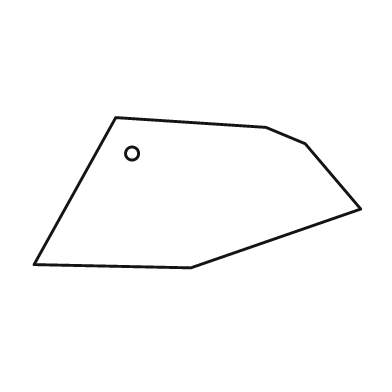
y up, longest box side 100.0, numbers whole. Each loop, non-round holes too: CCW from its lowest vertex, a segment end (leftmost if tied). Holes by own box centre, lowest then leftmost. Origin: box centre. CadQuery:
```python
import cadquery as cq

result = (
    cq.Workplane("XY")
    .moveTo(-2.0, -23.0)
    .lineTo(50.0, -5.0)
    .lineTo(33.0, 15.0)
    .lineTo(21.0, 20.0)
    .lineTo(-25.0, 23.0)
    .lineTo(-50.0, -22.0)
    .close()
    .moveTo(-20.0, 12.0)
    .circle(2.0)
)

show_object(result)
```